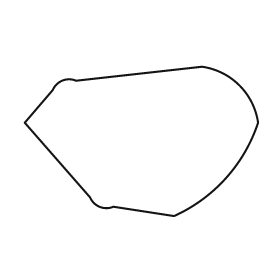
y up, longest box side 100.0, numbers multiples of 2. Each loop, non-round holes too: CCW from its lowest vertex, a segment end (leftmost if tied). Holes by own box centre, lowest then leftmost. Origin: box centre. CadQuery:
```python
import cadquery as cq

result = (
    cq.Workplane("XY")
    .moveTo(14.0, -32.0)
    .threePointArc((36.0, -16.0), (50.0, 8.0))
    .threePointArc((42.0, 24.0), (26.0, 32.0))
    .lineTo(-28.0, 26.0)
    .threePointArc((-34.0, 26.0), (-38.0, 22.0))
    .lineTo(-50.0, 8.0)
    .lineTo(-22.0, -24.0)
    .threePointArc((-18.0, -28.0), (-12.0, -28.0))
    .close()
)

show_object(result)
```